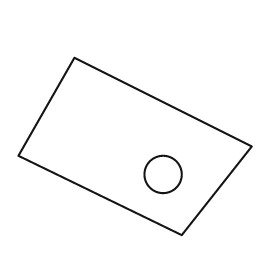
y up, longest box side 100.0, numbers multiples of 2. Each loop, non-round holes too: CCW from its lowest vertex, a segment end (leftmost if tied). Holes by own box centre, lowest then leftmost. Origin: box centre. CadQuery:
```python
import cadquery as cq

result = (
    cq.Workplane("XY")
    .moveTo(20.0, -38.0)
    .lineTo(50.0, 0.0)
    .lineTo(-26.0, 38.0)
    .lineTo(-50.0, -4.0)
    .close()
    .moveTo(12.0, -12.0)
    .circle(8.0)
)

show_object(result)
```